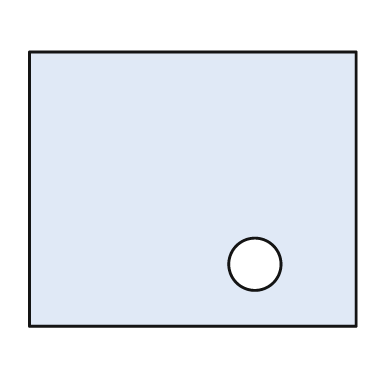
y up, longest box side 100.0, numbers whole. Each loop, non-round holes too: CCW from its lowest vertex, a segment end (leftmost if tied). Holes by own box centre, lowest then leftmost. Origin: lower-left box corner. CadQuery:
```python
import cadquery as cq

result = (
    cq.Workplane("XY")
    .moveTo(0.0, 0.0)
    .lineTo(100.0, 0.0)
    .lineTo(100.0, 84.0)
    .lineTo(0.0, 84.0)
    .close()
    .moveTo(69.0, 19.0)
    .circle(8.0)
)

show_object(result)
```